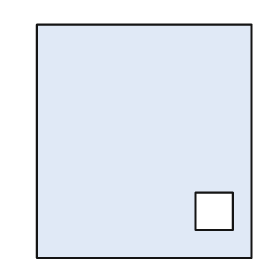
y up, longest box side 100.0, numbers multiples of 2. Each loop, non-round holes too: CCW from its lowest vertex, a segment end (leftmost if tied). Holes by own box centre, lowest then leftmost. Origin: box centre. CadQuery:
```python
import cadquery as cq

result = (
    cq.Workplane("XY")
    .moveTo(-46.0, -50.0)
    .lineTo(46.0, -50.0)
    .lineTo(46.0, 50.0)
    .lineTo(-46.0, 50.0)
    .close()
    .moveTo(22.0, -38.0)
    .lineTo(38.0, -38.0)
    .lineTo(38.0, -22.0)
    .lineTo(22.0, -22.0)
    .close()
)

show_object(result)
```